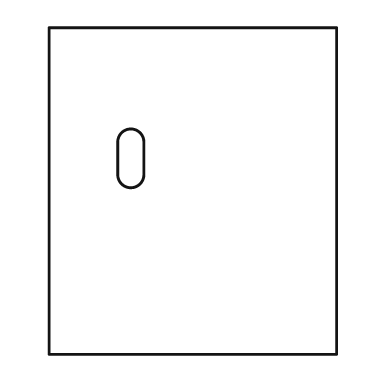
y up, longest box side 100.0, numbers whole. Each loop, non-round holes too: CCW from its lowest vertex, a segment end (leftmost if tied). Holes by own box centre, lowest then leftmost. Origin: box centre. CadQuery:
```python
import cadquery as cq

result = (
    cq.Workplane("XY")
    .moveTo(-44.0, -50.0)
    .lineTo(44.0, -50.0)
    .lineTo(44.0, 50.0)
    .lineTo(-44.0, 50.0)
    .close()
    .moveTo(-23.0, 5.0)
    .threePointArc((-19.0, 1.0), (-15.0, 5.0))
    .lineTo(-15.0, 15.0)
    .threePointArc((-19.0, 19.0), (-23.0, 15.0))
    .close()
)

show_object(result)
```